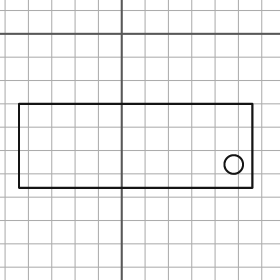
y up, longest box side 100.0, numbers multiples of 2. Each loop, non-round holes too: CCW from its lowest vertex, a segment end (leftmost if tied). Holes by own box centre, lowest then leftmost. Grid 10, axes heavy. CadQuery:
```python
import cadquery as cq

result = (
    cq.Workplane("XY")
    .moveTo(-44.0, -66.0)
    .lineTo(56.0, -66.0)
    .lineTo(56.0, -30.0)
    .lineTo(-44.0, -30.0)
    .close()
    .moveTo(48.0, -56.0)
    .circle(4.0)
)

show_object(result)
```